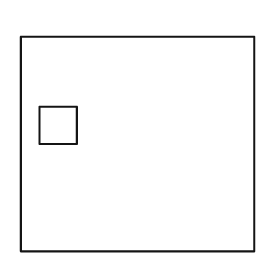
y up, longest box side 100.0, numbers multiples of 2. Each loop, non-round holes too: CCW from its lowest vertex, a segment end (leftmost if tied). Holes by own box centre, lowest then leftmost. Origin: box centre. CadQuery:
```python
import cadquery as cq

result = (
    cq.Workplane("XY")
    .moveTo(-50.0, -46.0)
    .lineTo(50.0, -46.0)
    .lineTo(50.0, 46.0)
    .lineTo(-50.0, 46.0)
    .close()
    .moveTo(-42.0, 0.0)
    .lineTo(-26.0, 0.0)
    .lineTo(-26.0, 16.0)
    .lineTo(-42.0, 16.0)
    .close()
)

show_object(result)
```